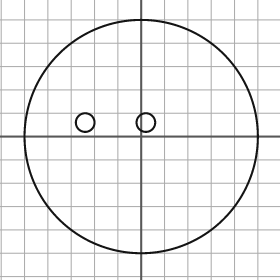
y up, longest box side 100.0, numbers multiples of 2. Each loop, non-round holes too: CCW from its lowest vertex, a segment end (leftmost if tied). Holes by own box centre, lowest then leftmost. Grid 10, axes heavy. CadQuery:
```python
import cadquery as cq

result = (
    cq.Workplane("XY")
    .moveTo(0.0, 0.0)
    .circle(50.0)
    .moveTo(-24.0, 6.0)
    .circle(4.0)
    .moveTo(2.0, 6.0)
    .circle(4.0)
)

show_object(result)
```